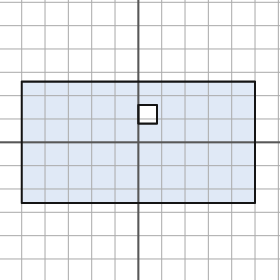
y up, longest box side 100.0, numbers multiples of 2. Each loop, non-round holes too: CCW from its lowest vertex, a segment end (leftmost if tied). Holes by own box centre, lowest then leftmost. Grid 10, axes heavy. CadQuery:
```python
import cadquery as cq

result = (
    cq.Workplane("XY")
    .moveTo(-50.0, -26.0)
    .lineTo(50.0, -26.0)
    .lineTo(50.0, 26.0)
    .lineTo(-50.0, 26.0)
    .close()
    .moveTo(0.0, 8.0)
    .lineTo(8.0, 8.0)
    .lineTo(8.0, 16.0)
    .lineTo(0.0, 16.0)
    .close()
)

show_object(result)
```